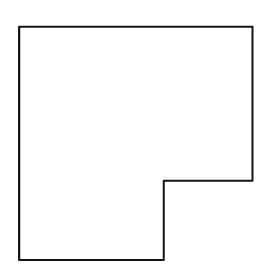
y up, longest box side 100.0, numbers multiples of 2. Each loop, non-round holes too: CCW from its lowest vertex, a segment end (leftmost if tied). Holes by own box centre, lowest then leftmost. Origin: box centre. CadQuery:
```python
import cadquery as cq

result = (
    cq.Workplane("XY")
    .moveTo(-50.0, -50.0)
    .lineTo(12.0, -50.0)
    .lineTo(12.0, -16.0)
    .lineTo(50.0, -16.0)
    .lineTo(50.0, 50.0)
    .lineTo(-50.0, 50.0)
    .close()
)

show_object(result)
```